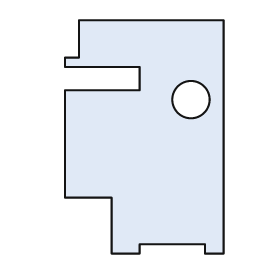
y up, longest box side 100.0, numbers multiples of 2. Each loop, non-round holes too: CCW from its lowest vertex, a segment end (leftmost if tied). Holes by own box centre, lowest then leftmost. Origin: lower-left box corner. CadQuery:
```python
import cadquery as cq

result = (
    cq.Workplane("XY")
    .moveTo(20.0, 0.0)
    .lineTo(32.0, 0.0)
    .lineTo(32.0, 4.0)
    .lineTo(60.0, 4.0)
    .lineTo(60.0, 0.0)
    .lineTo(68.0, 0.0)
    .lineTo(68.0, 100.0)
    .lineTo(6.0, 100.0)
    .lineTo(6.0, 84.0)
    .lineTo(0.0, 84.0)
    .lineTo(0.0, 80.0)
    .lineTo(32.0, 80.0)
    .lineTo(32.0, 70.0)
    .lineTo(0.0, 70.0)
    .lineTo(0.0, 24.0)
    .lineTo(20.0, 24.0)
    .close()
    .moveTo(54.0, 66.0)
    .circle(8.0)
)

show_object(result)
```